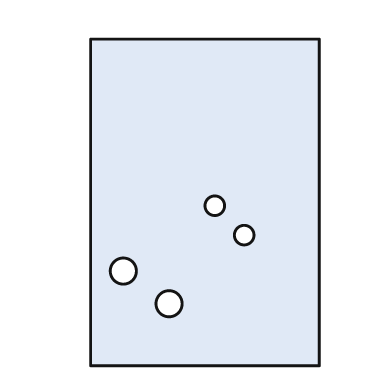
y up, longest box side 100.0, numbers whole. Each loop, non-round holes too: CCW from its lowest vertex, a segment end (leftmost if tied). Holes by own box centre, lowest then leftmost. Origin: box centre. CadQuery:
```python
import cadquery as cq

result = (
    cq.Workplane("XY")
    .moveTo(-35.0, -50.0)
    .lineTo(35.0, -50.0)
    .lineTo(35.0, 50.0)
    .lineTo(-35.0, 50.0)
    .close()
    .moveTo(-11.0, -31.0)
    .circle(4.0)
    .moveTo(-25.0, -21.0)
    .circle(4.0)
    .moveTo(12.0, -10.0)
    .circle(3.0)
    .moveTo(3.0, -1.0)
    .circle(3.0)
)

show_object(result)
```